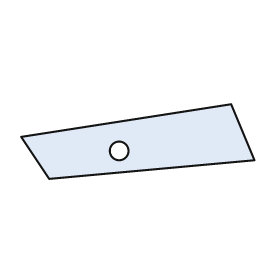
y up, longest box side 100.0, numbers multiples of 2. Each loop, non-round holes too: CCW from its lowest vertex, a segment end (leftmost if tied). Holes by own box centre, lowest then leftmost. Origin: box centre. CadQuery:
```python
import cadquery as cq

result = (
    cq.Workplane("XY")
    .moveTo(-38.0, -16.0)
    .lineTo(50.0, -8.0)
    .lineTo(40.0, 16.0)
    .lineTo(-50.0, 2.0)
    .close()
    .moveTo(-8.0, -4.0)
    .circle(4.0)
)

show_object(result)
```